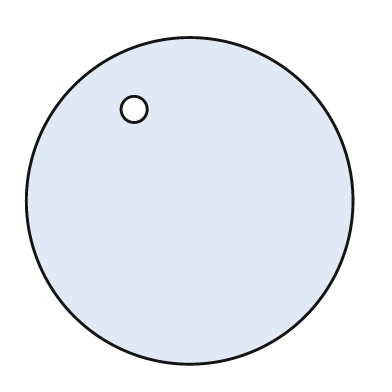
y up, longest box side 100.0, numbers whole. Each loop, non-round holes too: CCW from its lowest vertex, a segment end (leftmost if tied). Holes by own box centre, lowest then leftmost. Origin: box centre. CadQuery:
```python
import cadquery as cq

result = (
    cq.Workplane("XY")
    .moveTo(0.0, 0.0)
    .circle(50.0)
    .moveTo(-17.0, 28.0)
    .circle(4.0)
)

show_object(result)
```